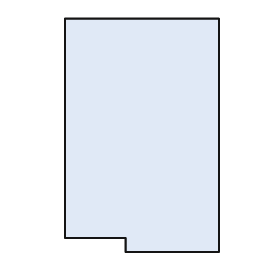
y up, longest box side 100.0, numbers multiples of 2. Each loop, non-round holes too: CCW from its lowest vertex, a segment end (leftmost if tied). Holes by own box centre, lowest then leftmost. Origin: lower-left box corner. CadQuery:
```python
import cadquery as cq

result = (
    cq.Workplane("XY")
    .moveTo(26.0, 0.0)
    .lineTo(66.0, 0.0)
    .lineTo(66.0, 100.0)
    .lineTo(0.0, 100.0)
    .lineTo(0.0, 6.0)
    .lineTo(26.0, 6.0)
    .close()
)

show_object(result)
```